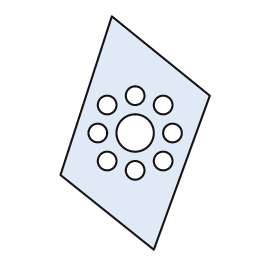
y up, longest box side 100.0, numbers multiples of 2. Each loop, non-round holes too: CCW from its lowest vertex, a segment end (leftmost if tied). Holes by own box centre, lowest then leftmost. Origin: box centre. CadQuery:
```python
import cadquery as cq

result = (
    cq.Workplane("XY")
    .moveTo(8.0, -50.0)
    .lineTo(32.0, 16.0)
    .lineTo(-10.0, 50.0)
    .lineTo(-32.0, -18.0)
    .close()
    .moveTo(0.0, -16.0)
    .circle(4.0)
    .moveTo(-12.0, -12.0)
    .circle(4.0)
    .moveTo(12.0, -12.0)
    .circle(4.0)
    .moveTo(-16.0, 0.0)
    .circle(4.0)
    .moveTo(0.0, 0.0)
    .circle(8.0)
    .moveTo(16.0, 0.0)
    .circle(4.0)
    .moveTo(-12.0, 12.0)
    .circle(4.0)
    .moveTo(12.0, 12.0)
    .circle(4.0)
    .moveTo(0.0, 16.0)
    .circle(4.0)
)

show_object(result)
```